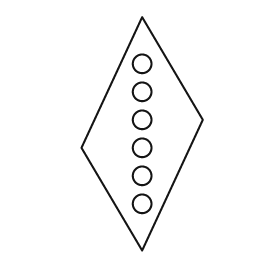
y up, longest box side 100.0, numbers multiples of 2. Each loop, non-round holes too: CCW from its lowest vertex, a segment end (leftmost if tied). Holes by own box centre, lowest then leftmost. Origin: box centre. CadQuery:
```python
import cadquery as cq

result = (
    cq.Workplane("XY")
    .moveTo(0.0, -50.0)
    .lineTo(26.0, 6.0)
    .lineTo(0.0, 50.0)
    .lineTo(-26.0, -6.0)
    .close()
    .moveTo(0.0, -30.0)
    .circle(4.0)
    .moveTo(0.0, -18.0)
    .circle(4.0)
    .moveTo(0.0, -6.0)
    .circle(4.0)
    .moveTo(0.0, 6.0)
    .circle(4.0)
    .moveTo(0.0, 18.0)
    .circle(4.0)
    .moveTo(0.0, 30.0)
    .circle(4.0)
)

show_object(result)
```